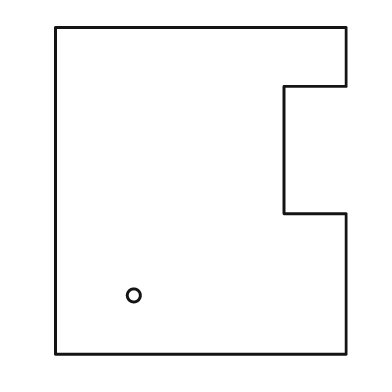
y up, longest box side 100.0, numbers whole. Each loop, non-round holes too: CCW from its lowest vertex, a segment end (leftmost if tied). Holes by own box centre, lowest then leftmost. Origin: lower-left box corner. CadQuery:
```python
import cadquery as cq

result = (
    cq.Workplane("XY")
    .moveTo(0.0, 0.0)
    .lineTo(89.0, 0.0)
    .lineTo(89.0, 43.0)
    .lineTo(70.0, 43.0)
    .lineTo(70.0, 82.0)
    .lineTo(89.0, 82.0)
    .lineTo(89.0, 100.0)
    .lineTo(0.0, 100.0)
    .close()
    .moveTo(24.0, 18.0)
    .circle(2.0)
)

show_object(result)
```